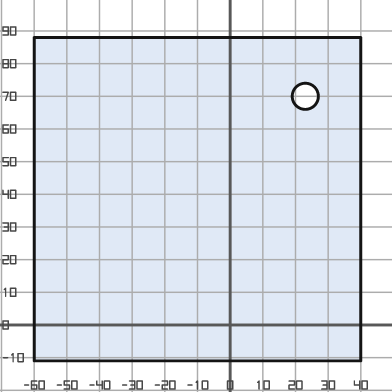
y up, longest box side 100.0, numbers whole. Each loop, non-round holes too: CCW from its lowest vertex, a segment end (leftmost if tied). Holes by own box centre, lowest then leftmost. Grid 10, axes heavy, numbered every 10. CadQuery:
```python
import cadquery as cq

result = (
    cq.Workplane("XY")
    .moveTo(-60.0, -11.0)
    .lineTo(40.0, -11.0)
    .lineTo(40.0, 88.0)
    .lineTo(-60.0, 88.0)
    .close()
    .moveTo(23.0, 70.0)
    .circle(4.0)
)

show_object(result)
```